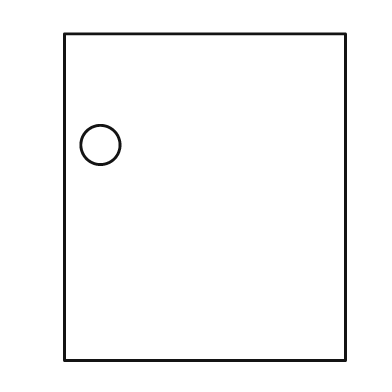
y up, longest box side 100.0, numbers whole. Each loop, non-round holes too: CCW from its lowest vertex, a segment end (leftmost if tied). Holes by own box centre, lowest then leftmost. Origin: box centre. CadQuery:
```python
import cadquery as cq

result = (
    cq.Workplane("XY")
    .moveTo(-43.0, -50.0)
    .lineTo(43.0, -50.0)
    .lineTo(43.0, 50.0)
    .lineTo(-43.0, 50.0)
    .close()
    .moveTo(-32.0, 16.0)
    .circle(6.0)
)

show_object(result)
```